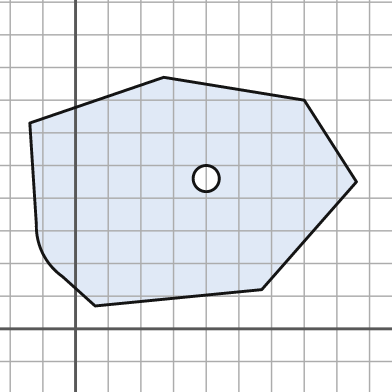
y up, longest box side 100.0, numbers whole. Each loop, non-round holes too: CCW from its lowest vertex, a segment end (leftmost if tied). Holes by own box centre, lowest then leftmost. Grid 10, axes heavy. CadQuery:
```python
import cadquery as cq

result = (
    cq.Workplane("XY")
    .moveTo(6.0, 7.0)
    .lineTo(57.0, 12.0)
    .lineTo(86.0, 45.0)
    .lineTo(70.0, 70.0)
    .lineTo(27.0, 77.0)
    .lineTo(-14.0, 63.0)
    .lineTo(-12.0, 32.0)
    .threePointArc((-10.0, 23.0), (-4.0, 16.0))
    .close()
    .moveTo(40.0, 46.0)
    .circle(4.0)
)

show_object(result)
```